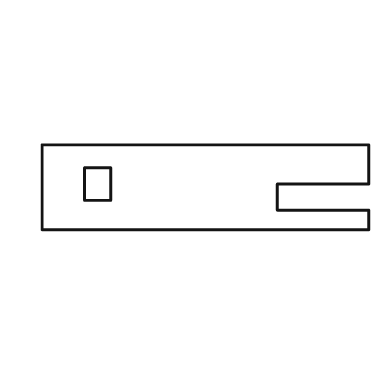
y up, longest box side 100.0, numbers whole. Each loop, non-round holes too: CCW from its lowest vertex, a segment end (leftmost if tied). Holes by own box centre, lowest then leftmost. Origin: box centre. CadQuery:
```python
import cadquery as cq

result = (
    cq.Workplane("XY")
    .moveTo(-50.0, -13.0)
    .lineTo(50.0, -13.0)
    .lineTo(50.0, -7.0)
    .lineTo(22.0, -7.0)
    .lineTo(22.0, 1.0)
    .lineTo(50.0, 1.0)
    .lineTo(50.0, 13.0)
    .lineTo(-50.0, 13.0)
    .close()
    .moveTo(-37.0, -4.0)
    .lineTo(-29.0, -4.0)
    .lineTo(-29.0, 6.0)
    .lineTo(-37.0, 6.0)
    .close()
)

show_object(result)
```